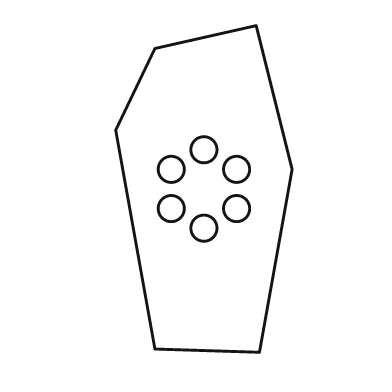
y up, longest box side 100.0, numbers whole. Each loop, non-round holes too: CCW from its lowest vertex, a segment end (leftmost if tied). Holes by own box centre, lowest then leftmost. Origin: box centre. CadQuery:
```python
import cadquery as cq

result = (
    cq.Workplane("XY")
    .moveTo(17.0, -50.0)
    .lineTo(27.0, 6.0)
    .lineTo(16.0, 50.0)
    .lineTo(-15.0, 43.0)
    .lineTo(-27.0, 18.0)
    .lineTo(-15.0, -49.0)
    .close()
    .moveTo(0.0, -12.0)
    .circle(4.0)
    .moveTo(-10.0, -6.0)
    .circle(4.0)
    .moveTo(10.0, -6.0)
    .circle(4.0)
    .moveTo(-10.0, 6.0)
    .circle(4.0)
    .moveTo(10.0, 6.0)
    .circle(4.0)
    .moveTo(0.0, 12.0)
    .circle(4.0)
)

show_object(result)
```